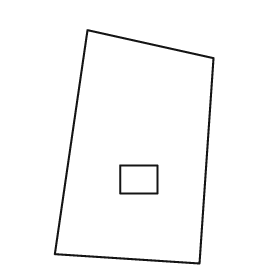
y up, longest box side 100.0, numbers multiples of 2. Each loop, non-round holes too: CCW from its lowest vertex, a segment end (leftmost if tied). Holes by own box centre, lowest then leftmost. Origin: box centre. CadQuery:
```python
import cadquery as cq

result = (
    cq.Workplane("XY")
    .moveTo(28.0, -50.0)
    .lineTo(34.0, 38.0)
    .lineTo(-20.0, 50.0)
    .lineTo(-34.0, -46.0)
    .close()
    .moveTo(-6.0, -20.0)
    .lineTo(10.0, -20.0)
    .lineTo(10.0, -8.0)
    .lineTo(-6.0, -8.0)
    .close()
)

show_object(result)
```